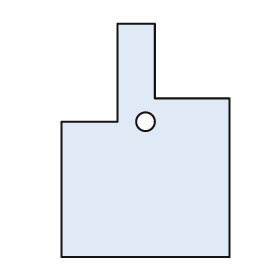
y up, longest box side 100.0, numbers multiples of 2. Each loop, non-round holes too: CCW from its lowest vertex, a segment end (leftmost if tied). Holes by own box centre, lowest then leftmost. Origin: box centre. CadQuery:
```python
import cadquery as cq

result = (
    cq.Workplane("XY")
    .moveTo(-36.0, -50.0)
    .lineTo(36.0, -50.0)
    .lineTo(36.0, 18.0)
    .lineTo(4.0, 18.0)
    .lineTo(4.0, 50.0)
    .lineTo(-12.0, 50.0)
    .lineTo(-12.0, 8.0)
    .lineTo(-36.0, 8.0)
    .close()
    .moveTo(0.0, 8.0)
    .circle(4.0)
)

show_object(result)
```